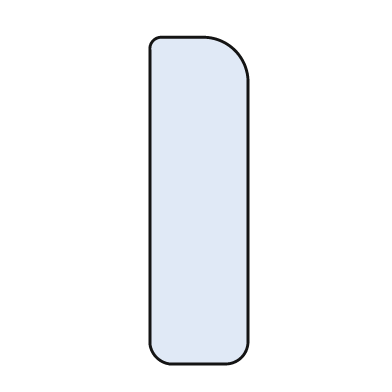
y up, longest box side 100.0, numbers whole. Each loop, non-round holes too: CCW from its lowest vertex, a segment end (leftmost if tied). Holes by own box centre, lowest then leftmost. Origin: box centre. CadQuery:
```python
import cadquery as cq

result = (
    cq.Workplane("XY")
    .moveTo(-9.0, -50.0)
    .lineTo(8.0, -50.0)
    .threePointArc((13.0, -48.0), (15.0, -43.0))
    .lineTo(15.0, 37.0)
    .threePointArc((11.0, 46.0), (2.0, 50.0))
    .lineTo(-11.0, 50.0)
    .threePointArc((-14.0, 49.0), (-15.0, 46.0))
    .lineTo(-15.0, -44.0)
    .threePointArc((-13.0, -48.0), (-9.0, -50.0))
    .close()
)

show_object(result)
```